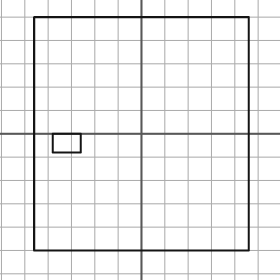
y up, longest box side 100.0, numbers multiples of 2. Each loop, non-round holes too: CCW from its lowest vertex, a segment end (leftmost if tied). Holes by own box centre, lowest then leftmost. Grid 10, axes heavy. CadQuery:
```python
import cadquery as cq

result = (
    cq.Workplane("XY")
    .moveTo(-46.0, -50.0)
    .lineTo(46.0, -50.0)
    .lineTo(46.0, 50.0)
    .lineTo(-46.0, 50.0)
    .close()
    .moveTo(-38.0, -8.0)
    .lineTo(-26.0, -8.0)
    .lineTo(-26.0, 0.0)
    .lineTo(-38.0, 0.0)
    .close()
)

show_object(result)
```